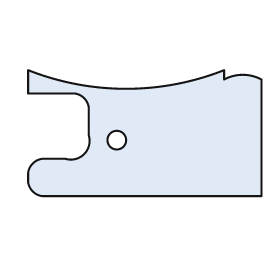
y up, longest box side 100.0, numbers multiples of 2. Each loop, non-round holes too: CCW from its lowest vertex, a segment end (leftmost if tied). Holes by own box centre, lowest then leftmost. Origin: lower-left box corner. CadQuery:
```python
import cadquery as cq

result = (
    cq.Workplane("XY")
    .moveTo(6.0, 0.0)
    .lineTo(100.0, 0.0)
    .lineTo(100.0, 50.0)
    .threePointArc((92.0, 52.0), (84.0, 50.0))
    .lineTo(84.0, 54.0)
    .threePointArc((42.0, 46.0), (0.0, 54.0))
    .lineTo(0.0, 44.0)
    .lineTo(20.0, 44.0)
    .threePointArc((24.0, 42.0), (26.0, 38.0))
    .lineTo(26.0, 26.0)
    .threePointArc((24.0, 18.0), (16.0, 16.0))
    .lineTo(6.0, 16.0)
    .threePointArc((2.0, 14.0), (0.0, 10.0))
    .lineTo(0.0, 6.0)
    .threePointArc((2.0, 2.0), (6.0, 0.0))
    .close()
    .moveTo(38.0, 24.0)
    .circle(4.0)
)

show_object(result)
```